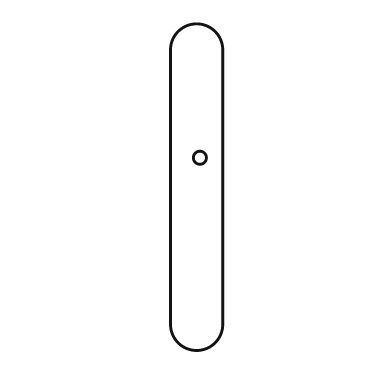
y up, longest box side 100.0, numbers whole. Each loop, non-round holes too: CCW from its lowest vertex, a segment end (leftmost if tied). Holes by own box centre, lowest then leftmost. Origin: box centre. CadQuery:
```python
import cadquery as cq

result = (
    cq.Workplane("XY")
    .moveTo(-8.0, -42.0)
    .threePointArc((0.0, -50.0), (8.0, -42.0))
    .lineTo(8.0, 42.0)
    .threePointArc((0.0, 50.0), (-8.0, 42.0))
    .close()
    .moveTo(1.0, 9.0)
    .circle(2.0)
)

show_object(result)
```